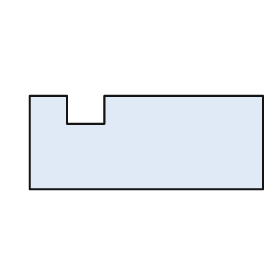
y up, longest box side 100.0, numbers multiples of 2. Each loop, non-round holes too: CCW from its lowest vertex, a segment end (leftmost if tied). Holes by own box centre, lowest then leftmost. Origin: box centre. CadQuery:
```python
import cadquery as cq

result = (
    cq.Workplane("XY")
    .moveTo(-50.0, -20.0)
    .lineTo(50.0, -20.0)
    .lineTo(50.0, 20.0)
    .lineTo(-18.0, 20.0)
    .lineTo(-18.0, 8.0)
    .lineTo(-34.0, 8.0)
    .lineTo(-34.0, 20.0)
    .lineTo(-50.0, 20.0)
    .close()
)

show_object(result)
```